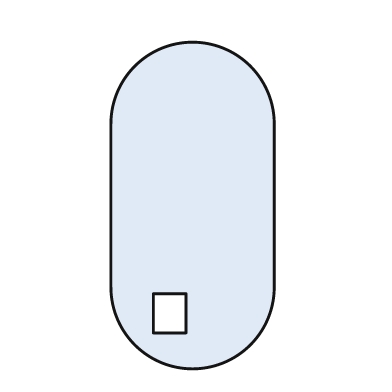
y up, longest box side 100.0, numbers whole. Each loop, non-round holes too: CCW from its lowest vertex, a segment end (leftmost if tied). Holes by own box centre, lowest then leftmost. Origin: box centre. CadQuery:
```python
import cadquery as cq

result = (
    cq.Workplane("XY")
    .moveTo(-25.0, -25.0)
    .threePointArc((0.0, -50.0), (25.0, -25.0))
    .lineTo(25.0, 25.0)
    .threePointArc((0.0, 50.0), (-25.0, 25.0))
    .close()
    .moveTo(-12.0, -39.0)
    .lineTo(-2.0, -39.0)
    .lineTo(-2.0, -27.0)
    .lineTo(-12.0, -27.0)
    .close()
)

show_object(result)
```